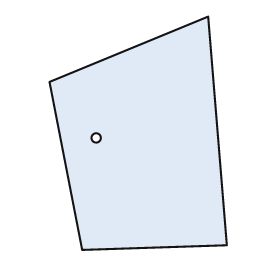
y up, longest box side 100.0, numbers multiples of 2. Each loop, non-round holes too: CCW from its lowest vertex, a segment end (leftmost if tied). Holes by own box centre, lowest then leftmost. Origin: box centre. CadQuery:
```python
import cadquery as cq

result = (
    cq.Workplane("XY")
    .moveTo(-24.0, -50.0)
    .lineTo(38.0, -48.0)
    .lineTo(30.0, 50.0)
    .lineTo(-38.0, 22.0)
    .close()
    .moveTo(-18.0, -2.0)
    .circle(2.0)
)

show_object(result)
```